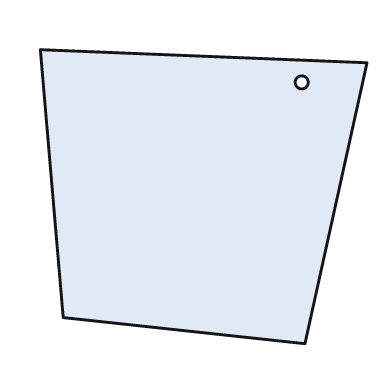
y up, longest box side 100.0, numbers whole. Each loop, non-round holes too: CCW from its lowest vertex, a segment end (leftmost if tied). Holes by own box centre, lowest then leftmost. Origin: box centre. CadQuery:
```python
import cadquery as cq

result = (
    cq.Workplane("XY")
    .moveTo(31.0, -45.0)
    .lineTo(50.0, 41.0)
    .lineTo(-50.0, 45.0)
    .lineTo(-43.0, -37.0)
    .close()
    .moveTo(30.0, 35.0)
    .circle(2.0)
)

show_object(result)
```